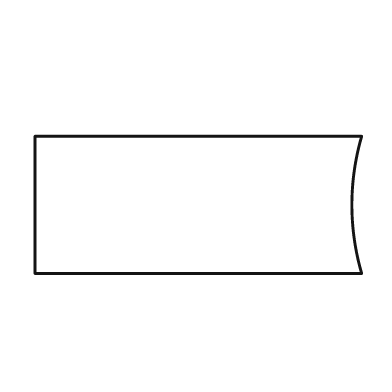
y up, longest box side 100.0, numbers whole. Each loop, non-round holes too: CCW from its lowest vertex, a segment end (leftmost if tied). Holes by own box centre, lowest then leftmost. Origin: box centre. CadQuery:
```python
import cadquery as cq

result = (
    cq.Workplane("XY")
    .moveTo(-50.0, -21.0)
    .lineTo(50.0, -21.0)
    .threePointArc((47.0, 0.0), (50.0, 21.0))
    .lineTo(-50.0, 21.0)
    .close()
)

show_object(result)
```